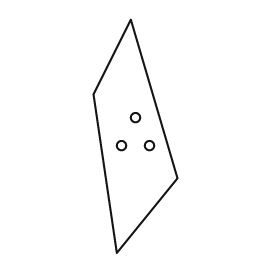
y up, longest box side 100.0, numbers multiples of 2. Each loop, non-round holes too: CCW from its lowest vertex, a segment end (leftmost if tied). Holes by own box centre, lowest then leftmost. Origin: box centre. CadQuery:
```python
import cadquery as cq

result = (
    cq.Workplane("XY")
    .moveTo(-8.0, -50.0)
    .lineTo(18.0, -18.0)
    .lineTo(-2.0, 50.0)
    .lineTo(-18.0, 18.0)
    .close()
    .moveTo(-6.0, -4.0)
    .circle(2.0)
    .moveTo(6.0, -4.0)
    .circle(2.0)
    .moveTo(0.0, 8.0)
    .circle(2.0)
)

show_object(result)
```